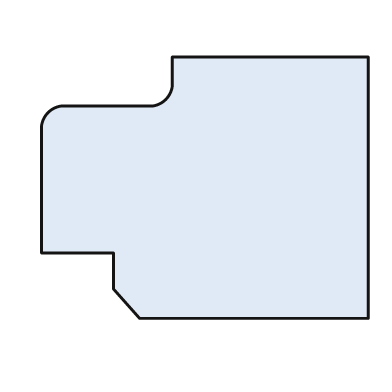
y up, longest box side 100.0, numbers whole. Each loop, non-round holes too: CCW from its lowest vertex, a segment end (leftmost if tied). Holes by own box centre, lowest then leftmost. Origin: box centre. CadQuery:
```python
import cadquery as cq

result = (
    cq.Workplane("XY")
    .moveTo(-20.0, -40.0)
    .lineTo(50.0, -40.0)
    .lineTo(50.0, 40.0)
    .lineTo(-10.0, 40.0)
    .lineTo(-10.0, 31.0)
    .threePointArc((-12.0, 27.0), (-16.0, 25.0))
    .lineTo(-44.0, 25.0)
    .threePointArc((-48.0, 23.0), (-50.0, 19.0))
    .lineTo(-50.0, -20.0)
    .lineTo(-28.0, -20.0)
    .lineTo(-28.0, -31.0)
    .close()
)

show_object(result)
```